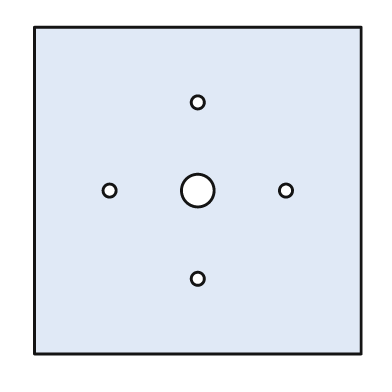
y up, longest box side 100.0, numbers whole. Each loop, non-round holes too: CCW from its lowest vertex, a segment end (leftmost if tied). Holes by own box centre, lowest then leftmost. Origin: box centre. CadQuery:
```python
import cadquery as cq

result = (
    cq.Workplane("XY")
    .moveTo(-50.0, -50.0)
    .lineTo(50.0, -50.0)
    .lineTo(50.0, 50.0)
    .lineTo(-50.0, 50.0)
    .close()
    .moveTo(0.0, -27.0)
    .circle(2.0)
    .moveTo(-27.0, 0.0)
    .circle(2.0)
    .moveTo(0.0, 0.0)
    .circle(5.0)
    .moveTo(27.0, 0.0)
    .circle(2.0)
    .moveTo(0.0, 27.0)
    .circle(2.0)
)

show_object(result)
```